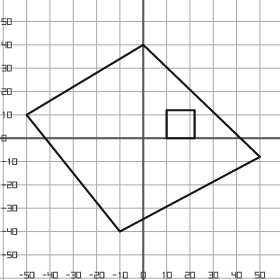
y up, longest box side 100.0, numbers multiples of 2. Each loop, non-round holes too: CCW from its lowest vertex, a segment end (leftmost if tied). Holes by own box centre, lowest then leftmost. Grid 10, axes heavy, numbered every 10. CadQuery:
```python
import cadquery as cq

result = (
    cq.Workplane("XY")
    .moveTo(-10.0, -40.0)
    .lineTo(50.0, -8.0)
    .lineTo(0.0, 40.0)
    .lineTo(-50.0, 10.0)
    .close()
    .moveTo(10.0, 0.0)
    .lineTo(22.0, 0.0)
    .lineTo(22.0, 12.0)
    .lineTo(10.0, 12.0)
    .close()
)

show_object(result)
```